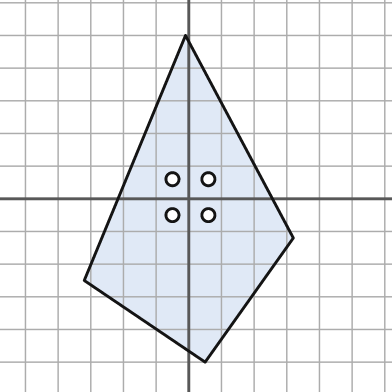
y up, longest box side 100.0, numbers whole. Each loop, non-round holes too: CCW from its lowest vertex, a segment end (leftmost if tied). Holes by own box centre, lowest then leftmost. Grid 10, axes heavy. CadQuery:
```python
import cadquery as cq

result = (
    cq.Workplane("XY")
    .moveTo(5.0, -50.0)
    .lineTo(32.0, -12.0)
    .lineTo(-1.0, 50.0)
    .lineTo(-32.0, -25.0)
    .close()
    .moveTo(-5.0, -5.0)
    .circle(2.0)
    .moveTo(6.0, -5.0)
    .circle(2.0)
    .moveTo(-5.0, 6.0)
    .circle(2.0)
    .moveTo(6.0, 6.0)
    .circle(2.0)
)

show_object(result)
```